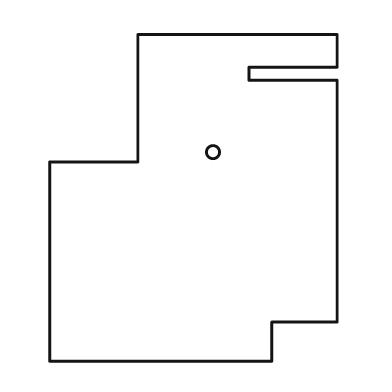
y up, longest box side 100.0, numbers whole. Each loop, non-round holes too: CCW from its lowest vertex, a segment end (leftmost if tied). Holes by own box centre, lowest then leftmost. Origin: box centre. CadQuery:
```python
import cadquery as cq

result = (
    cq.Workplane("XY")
    .moveTo(-44.0, -50.0)
    .lineTo(24.0, -50.0)
    .lineTo(24.0, -38.0)
    .lineTo(44.0, -38.0)
    .lineTo(44.0, 36.0)
    .lineTo(17.0, 36.0)
    .lineTo(17.0, 40.0)
    .lineTo(44.0, 40.0)
    .lineTo(44.0, 50.0)
    .lineTo(-17.0, 50.0)
    .lineTo(-17.0, 11.0)
    .lineTo(-44.0, 11.0)
    .close()
    .moveTo(6.0, 14.0)
    .circle(2.0)
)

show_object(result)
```